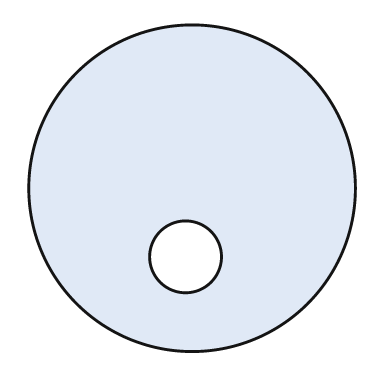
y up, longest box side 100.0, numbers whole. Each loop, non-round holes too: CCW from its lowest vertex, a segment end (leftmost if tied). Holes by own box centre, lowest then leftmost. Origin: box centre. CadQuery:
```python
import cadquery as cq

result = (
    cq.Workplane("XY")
    .moveTo(0.0, 0.0)
    .circle(50.0)
    .moveTo(-2.0, -21.0)
    .circle(11.0)
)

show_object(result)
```